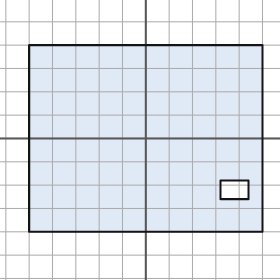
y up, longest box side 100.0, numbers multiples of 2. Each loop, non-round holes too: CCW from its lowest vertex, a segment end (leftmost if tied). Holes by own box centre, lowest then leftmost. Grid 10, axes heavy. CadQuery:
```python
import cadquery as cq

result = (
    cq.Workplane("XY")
    .moveTo(-50.0, -40.0)
    .lineTo(50.0, -40.0)
    .lineTo(50.0, 40.0)
    .lineTo(-50.0, 40.0)
    .close()
    .moveTo(32.0, -26.0)
    .lineTo(44.0, -26.0)
    .lineTo(44.0, -18.0)
    .lineTo(32.0, -18.0)
    .close()
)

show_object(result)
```